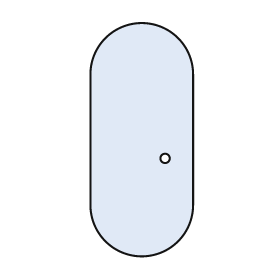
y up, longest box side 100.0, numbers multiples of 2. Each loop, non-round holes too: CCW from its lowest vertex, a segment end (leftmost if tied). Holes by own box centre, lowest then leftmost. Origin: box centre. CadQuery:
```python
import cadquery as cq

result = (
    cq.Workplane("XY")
    .moveTo(-22.0, -28.0)
    .threePointArc((0.0, -50.0), (22.0, -28.0))
    .lineTo(22.0, 28.0)
    .threePointArc((0.0, 50.0), (-22.0, 28.0))
    .close()
    .moveTo(10.0, -8.0)
    .circle(2.0)
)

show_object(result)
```